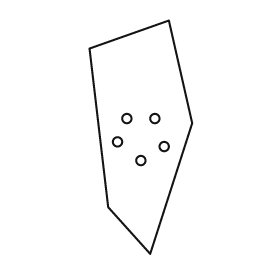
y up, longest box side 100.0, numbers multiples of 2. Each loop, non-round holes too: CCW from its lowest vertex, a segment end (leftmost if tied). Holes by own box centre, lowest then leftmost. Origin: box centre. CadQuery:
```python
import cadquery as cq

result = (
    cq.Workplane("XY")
    .moveTo(4.0, -50.0)
    .lineTo(22.0, 6.0)
    .lineTo(12.0, 50.0)
    .lineTo(-22.0, 38.0)
    .lineTo(-14.0, -30.0)
    .close()
    .moveTo(0.0, -10.0)
    .circle(2.0)
    .moveTo(10.0, -4.0)
    .circle(2.0)
    .moveTo(-10.0, -2.0)
    .circle(2.0)
    .moveTo(-6.0, 8.0)
    .circle(2.0)
    .moveTo(6.0, 8.0)
    .circle(2.0)
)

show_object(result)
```